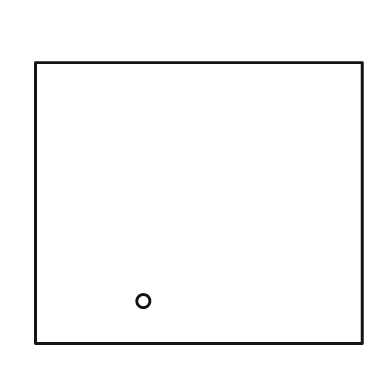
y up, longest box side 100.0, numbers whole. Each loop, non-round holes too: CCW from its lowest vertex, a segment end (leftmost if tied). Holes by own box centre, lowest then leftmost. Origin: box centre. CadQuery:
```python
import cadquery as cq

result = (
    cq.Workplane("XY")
    .moveTo(-50.0, -43.0)
    .lineTo(50.0, -43.0)
    .lineTo(50.0, 43.0)
    .lineTo(-50.0, 43.0)
    .close()
    .moveTo(-17.0, -30.0)
    .circle(2.0)
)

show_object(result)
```